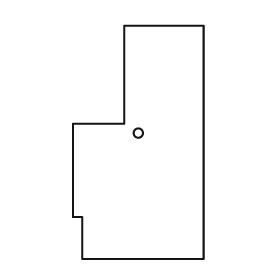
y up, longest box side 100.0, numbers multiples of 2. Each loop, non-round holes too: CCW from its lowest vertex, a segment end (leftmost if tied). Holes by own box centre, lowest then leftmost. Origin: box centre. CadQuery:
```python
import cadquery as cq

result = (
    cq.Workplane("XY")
    .moveTo(-24.0, -50.0)
    .lineTo(28.0, -50.0)
    .lineTo(28.0, 50.0)
    .lineTo(-6.0, 50.0)
    .lineTo(-6.0, 8.0)
    .lineTo(-28.0, 8.0)
    .lineTo(-28.0, -32.0)
    .lineTo(-24.0, -32.0)
    .close()
    .moveTo(0.0, 4.0)
    .circle(2.0)
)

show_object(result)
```